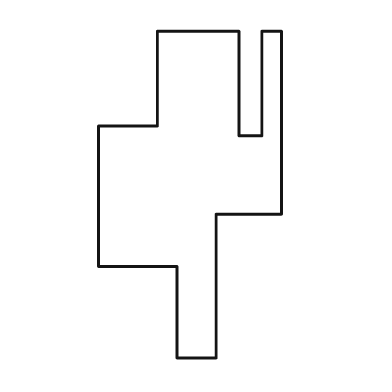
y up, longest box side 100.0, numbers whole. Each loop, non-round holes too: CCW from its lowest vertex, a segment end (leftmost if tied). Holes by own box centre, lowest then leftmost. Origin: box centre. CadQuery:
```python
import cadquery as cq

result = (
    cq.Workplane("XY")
    .moveTo(-4.0, -50.0)
    .lineTo(8.0, -50.0)
    .lineTo(8.0, -6.0)
    .lineTo(28.0, -6.0)
    .lineTo(28.0, 50.0)
    .lineTo(22.0, 50.0)
    .lineTo(22.0, 18.0)
    .lineTo(15.0, 18.0)
    .lineTo(15.0, 50.0)
    .lineTo(-10.0, 50.0)
    .lineTo(-10.0, 21.0)
    .lineTo(-28.0, 21.0)
    .lineTo(-28.0, -22.0)
    .lineTo(-4.0, -22.0)
    .close()
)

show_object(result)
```